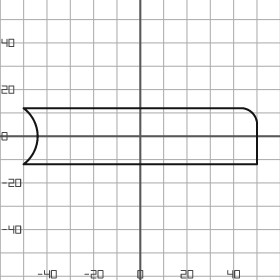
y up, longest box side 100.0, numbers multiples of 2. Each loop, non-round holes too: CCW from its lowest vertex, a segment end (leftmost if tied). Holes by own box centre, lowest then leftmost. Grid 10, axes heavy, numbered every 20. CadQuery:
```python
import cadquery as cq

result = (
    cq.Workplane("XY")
    .moveTo(-50.0, -12.0)
    .lineTo(50.0, -12.0)
    .lineTo(50.0, 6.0)
    .threePointArc((48.0, 10.0), (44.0, 12.0))
    .lineTo(-50.0, 12.0)
    .threePointArc((-44.0, 0.0), (-50.0, -12.0))
    .close()
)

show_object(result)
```